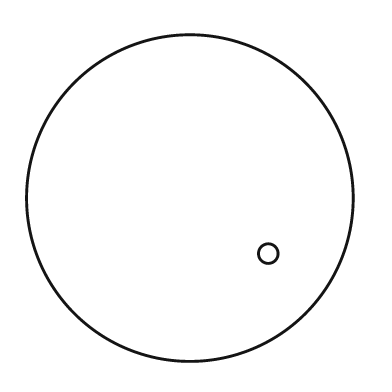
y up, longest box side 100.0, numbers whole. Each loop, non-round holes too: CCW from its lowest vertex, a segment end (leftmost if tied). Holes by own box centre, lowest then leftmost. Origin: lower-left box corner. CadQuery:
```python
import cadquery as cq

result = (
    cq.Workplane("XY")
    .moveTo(50.0, 50.0)
    .circle(50.0)
    .moveTo(74.0, 33.0)
    .circle(3.0)
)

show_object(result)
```